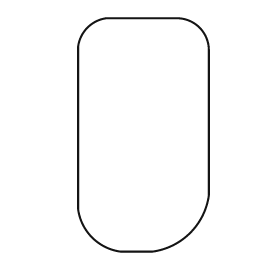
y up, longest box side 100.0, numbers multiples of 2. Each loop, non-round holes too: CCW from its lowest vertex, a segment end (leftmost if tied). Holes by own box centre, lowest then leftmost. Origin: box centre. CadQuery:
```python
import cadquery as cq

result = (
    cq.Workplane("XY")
    .moveTo(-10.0, -50.0)
    .lineTo(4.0, -50.0)
    .threePointArc((20.0, -42.0), (28.0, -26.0))
    .lineTo(28.0, 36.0)
    .threePointArc((24.0, 46.0), (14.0, 50.0))
    .lineTo(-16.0, 50.0)
    .threePointArc((-24.0, 46.0), (-28.0, 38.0))
    .lineTo(-28.0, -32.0)
    .threePointArc((-22.0, -44.0), (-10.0, -50.0))
    .close()
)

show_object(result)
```